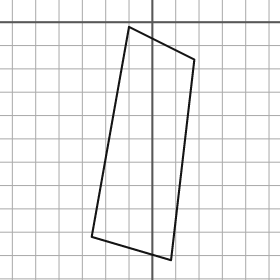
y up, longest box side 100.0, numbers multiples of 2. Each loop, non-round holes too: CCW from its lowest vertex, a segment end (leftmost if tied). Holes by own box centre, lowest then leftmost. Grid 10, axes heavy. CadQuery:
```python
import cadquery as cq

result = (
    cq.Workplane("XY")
    .moveTo(8.0, -102.0)
    .lineTo(18.0, -16.0)
    .lineTo(-10.0, -2.0)
    .lineTo(-26.0, -92.0)
    .close()
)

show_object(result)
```